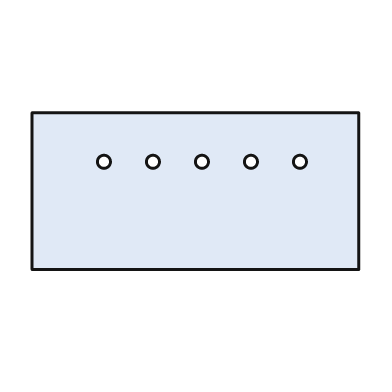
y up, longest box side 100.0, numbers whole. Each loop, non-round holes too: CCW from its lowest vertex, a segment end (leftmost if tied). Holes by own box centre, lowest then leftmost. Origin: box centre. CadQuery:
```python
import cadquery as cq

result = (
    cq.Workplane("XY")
    .moveTo(-50.0, -24.0)
    .lineTo(50.0, -24.0)
    .lineTo(50.0, 24.0)
    .lineTo(-50.0, 24.0)
    .close()
    .moveTo(-28.0, 9.0)
    .circle(2.0)
    .moveTo(-13.0, 9.0)
    .circle(2.0)
    .moveTo(2.0, 9.0)
    .circle(2.0)
    .moveTo(17.0, 9.0)
    .circle(2.0)
    .moveTo(32.0, 9.0)
    .circle(2.0)
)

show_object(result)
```